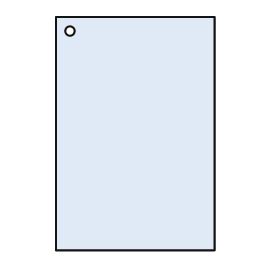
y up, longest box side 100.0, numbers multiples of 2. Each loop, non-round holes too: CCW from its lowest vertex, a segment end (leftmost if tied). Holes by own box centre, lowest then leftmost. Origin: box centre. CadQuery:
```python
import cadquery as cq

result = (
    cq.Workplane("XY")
    .moveTo(-34.0, -50.0)
    .lineTo(34.0, -50.0)
    .lineTo(34.0, 50.0)
    .lineTo(-34.0, 50.0)
    .close()
    .moveTo(-28.0, 44.0)
    .circle(2.0)
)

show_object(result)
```